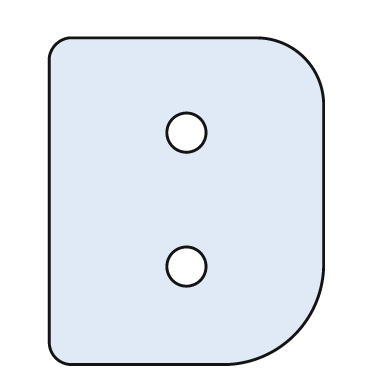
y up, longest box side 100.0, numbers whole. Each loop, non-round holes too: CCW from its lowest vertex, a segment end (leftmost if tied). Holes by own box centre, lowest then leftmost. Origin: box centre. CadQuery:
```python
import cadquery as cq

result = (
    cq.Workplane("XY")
    .moveTo(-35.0, -50.0)
    .lineTo(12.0, -50.0)
    .threePointArc((33.0, -41.0), (42.0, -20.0))
    .lineTo(42.0, 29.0)
    .threePointArc((36.0, 44.0), (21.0, 50.0))
    .lineTo(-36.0, 50.0)
    .threePointArc((-40.0, 48.0), (-42.0, 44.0))
    .lineTo(-42.0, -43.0)
    .threePointArc((-40.0, -48.0), (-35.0, -50.0))
    .close()
    .moveTo(0.0, -20.0)
    .circle(6.0)
    .moveTo(0.0, 21.0)
    .circle(6.0)
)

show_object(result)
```